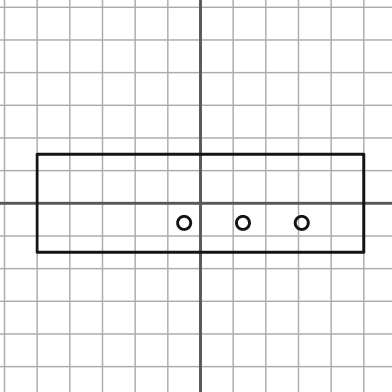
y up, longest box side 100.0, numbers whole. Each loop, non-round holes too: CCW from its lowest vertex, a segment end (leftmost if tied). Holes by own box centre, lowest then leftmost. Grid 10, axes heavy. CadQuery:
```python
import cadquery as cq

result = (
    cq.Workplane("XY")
    .moveTo(-50.0, -15.0)
    .lineTo(50.0, -15.0)
    .lineTo(50.0, 15.0)
    .lineTo(-50.0, 15.0)
    .close()
    .moveTo(-5.0, -6.0)
    .circle(2.0)
    .moveTo(13.0, -6.0)
    .circle(2.0)
    .moveTo(31.0, -6.0)
    .circle(2.0)
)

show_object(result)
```